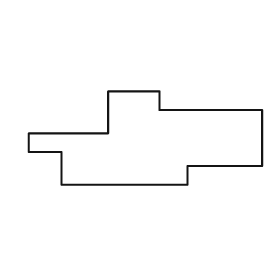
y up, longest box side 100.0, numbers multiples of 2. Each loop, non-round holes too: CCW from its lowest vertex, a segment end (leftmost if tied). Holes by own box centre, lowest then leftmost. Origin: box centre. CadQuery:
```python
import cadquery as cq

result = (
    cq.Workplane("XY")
    .moveTo(-36.0, -20.0)
    .lineTo(18.0, -20.0)
    .lineTo(18.0, -12.0)
    .lineTo(50.0, -12.0)
    .lineTo(50.0, 12.0)
    .lineTo(6.0, 12.0)
    .lineTo(6.0, 20.0)
    .lineTo(-16.0, 20.0)
    .lineTo(-16.0, 2.0)
    .lineTo(-50.0, 2.0)
    .lineTo(-50.0, -6.0)
    .lineTo(-36.0, -6.0)
    .close()
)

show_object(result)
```